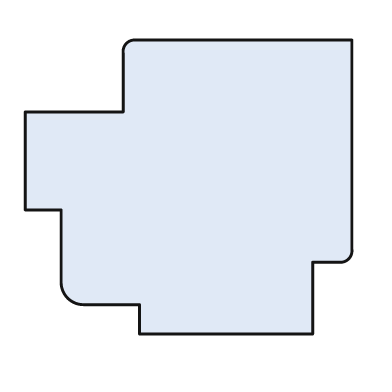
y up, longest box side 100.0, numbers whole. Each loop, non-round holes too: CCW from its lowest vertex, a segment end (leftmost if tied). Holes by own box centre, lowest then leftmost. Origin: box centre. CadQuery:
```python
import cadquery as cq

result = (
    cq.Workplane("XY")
    .moveTo(-15.0, -45.0)
    .lineTo(38.0, -45.0)
    .lineTo(38.0, -23.0)
    .lineTo(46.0, -23.0)
    .threePointArc((49.0, -22.0), (50.0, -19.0))
    .lineTo(50.0, 45.0)
    .lineTo(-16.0, 45.0)
    .threePointArc((-19.0, 44.0), (-20.0, 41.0))
    .lineTo(-20.0, 23.0)
    .lineTo(-50.0, 23.0)
    .lineTo(-50.0, -7.0)
    .lineTo(-39.0, -7.0)
    .lineTo(-39.0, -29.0)
    .threePointArc((-37.0, -34.0), (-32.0, -36.0))
    .lineTo(-15.0, -36.0)
    .close()
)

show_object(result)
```